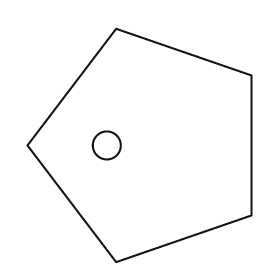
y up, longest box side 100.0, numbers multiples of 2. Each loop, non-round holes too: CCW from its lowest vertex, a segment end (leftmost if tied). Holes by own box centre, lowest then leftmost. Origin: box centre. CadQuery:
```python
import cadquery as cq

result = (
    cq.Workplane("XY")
    .moveTo(-10.0, -50.0)
    .lineTo(48.0, -30.0)
    .lineTo(48.0, 30.0)
    .lineTo(-10.0, 50.0)
    .lineTo(-48.0, 0.0)
    .close()
    .moveTo(-14.0, 0.0)
    .circle(6.0)
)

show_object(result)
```